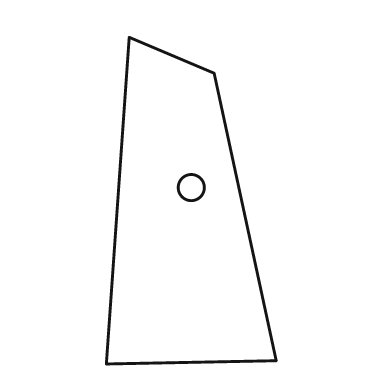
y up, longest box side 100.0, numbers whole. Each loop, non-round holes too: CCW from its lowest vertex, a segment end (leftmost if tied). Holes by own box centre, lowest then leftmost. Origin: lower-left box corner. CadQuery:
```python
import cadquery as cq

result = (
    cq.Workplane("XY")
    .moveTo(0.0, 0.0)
    .lineTo(52.0, 1.0)
    .lineTo(33.0, 89.0)
    .lineTo(7.0, 100.0)
    .close()
    .moveTo(26.0, 54.0)
    .circle(4.0)
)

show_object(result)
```